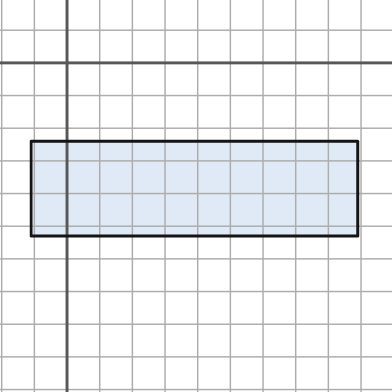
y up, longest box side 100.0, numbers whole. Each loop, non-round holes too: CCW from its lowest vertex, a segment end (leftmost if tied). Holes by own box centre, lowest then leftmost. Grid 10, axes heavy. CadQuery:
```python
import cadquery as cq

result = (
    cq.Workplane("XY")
    .moveTo(-11.0, -53.0)
    .lineTo(89.0, -53.0)
    .lineTo(89.0, -24.0)
    .lineTo(-11.0, -24.0)
    .close()
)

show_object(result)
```